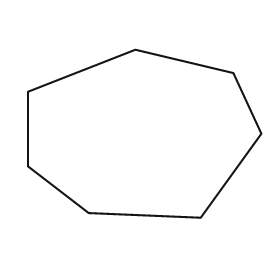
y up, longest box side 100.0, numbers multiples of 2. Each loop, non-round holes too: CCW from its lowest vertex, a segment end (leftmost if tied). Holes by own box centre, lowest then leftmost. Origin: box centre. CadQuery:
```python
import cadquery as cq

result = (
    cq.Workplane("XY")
    .moveTo(24.0, -36.0)
    .lineTo(50.0, 0.0)
    .lineTo(38.0, 26.0)
    .lineTo(-4.0, 36.0)
    .lineTo(-50.0, 18.0)
    .lineTo(-50.0, -14.0)
    .lineTo(-24.0, -34.0)
    .close()
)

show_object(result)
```